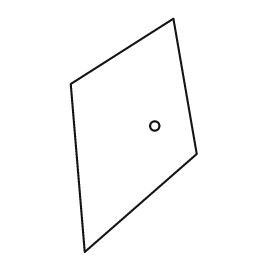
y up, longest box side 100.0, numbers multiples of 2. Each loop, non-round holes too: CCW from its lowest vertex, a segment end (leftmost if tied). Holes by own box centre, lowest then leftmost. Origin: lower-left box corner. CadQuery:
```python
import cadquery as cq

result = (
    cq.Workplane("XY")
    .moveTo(6.0, 0.0)
    .lineTo(54.0, 42.0)
    .lineTo(44.0, 100.0)
    .lineTo(0.0, 72.0)
    .close()
    .moveTo(36.0, 54.0)
    .circle(2.0)
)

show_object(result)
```